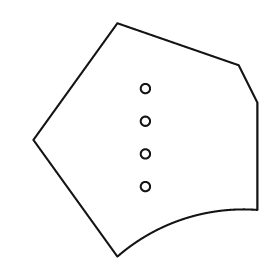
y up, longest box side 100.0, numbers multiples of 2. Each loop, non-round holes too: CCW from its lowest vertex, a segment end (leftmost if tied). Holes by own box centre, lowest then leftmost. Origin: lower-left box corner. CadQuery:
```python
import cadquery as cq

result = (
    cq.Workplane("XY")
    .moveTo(36.0, 0.0)
    .threePointArc((64.0, 16.0), (96.0, 20.0))
    .lineTo(96.0, 66.0)
    .lineTo(88.0, 82.0)
    .lineTo(36.0, 100.0)
    .lineTo(0.0, 50.0)
    .close()
    .moveTo(48.0, 30.0)
    .circle(2.0)
    .moveTo(48.0, 44.0)
    .circle(2.0)
    .moveTo(48.0, 58.0)
    .circle(2.0)
    .moveTo(48.0, 72.0)
    .circle(2.0)
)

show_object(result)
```